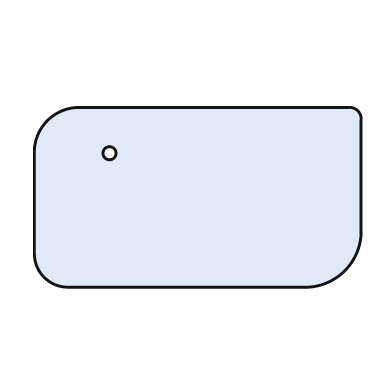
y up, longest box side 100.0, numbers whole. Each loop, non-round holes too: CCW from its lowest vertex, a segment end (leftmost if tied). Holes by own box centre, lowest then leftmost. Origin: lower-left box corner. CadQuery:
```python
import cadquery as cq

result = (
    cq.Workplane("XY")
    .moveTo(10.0, 0.0)
    .lineTo(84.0, 0.0)
    .threePointArc((95.0, 5.0), (100.0, 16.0))
    .lineTo(100.0, 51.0)
    .threePointArc((99.0, 54.0), (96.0, 55.0))
    .lineTo(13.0, 55.0)
    .threePointArc((4.0, 51.0), (0.0, 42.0))
    .lineTo(0.0, 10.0)
    .threePointArc((3.0, 3.0), (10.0, 0.0))
    .close()
    .moveTo(23.0, 41.0)
    .circle(2.0)
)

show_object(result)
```